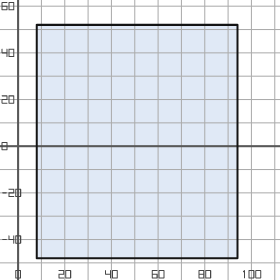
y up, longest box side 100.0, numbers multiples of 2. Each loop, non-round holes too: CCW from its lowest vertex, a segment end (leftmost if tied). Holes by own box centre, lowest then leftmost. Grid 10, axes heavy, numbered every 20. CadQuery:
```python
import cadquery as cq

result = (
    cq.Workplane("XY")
    .moveTo(8.0, -48.0)
    .lineTo(94.0, -48.0)
    .lineTo(94.0, 52.0)
    .lineTo(8.0, 52.0)
    .close()
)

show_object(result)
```